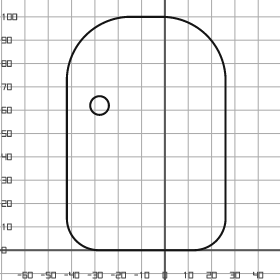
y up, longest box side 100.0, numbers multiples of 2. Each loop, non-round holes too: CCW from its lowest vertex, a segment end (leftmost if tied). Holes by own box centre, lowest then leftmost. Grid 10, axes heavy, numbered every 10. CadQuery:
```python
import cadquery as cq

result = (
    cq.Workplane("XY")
    .moveTo(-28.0, 0.0)
    .lineTo(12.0, 0.0)
    .threePointArc((22.0, 4.0), (26.0, 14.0))
    .lineTo(26.0, 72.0)
    .threePointArc((18.0, 92.0), (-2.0, 100.0))
    .lineTo(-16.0, 100.0)
    .threePointArc((-34.0, 92.0), (-42.0, 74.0))
    .lineTo(-42.0, 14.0)
    .threePointArc((-38.0, 4.0), (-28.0, 0.0))
    .close()
    .moveTo(-28.0, 62.0)
    .circle(4.0)
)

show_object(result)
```